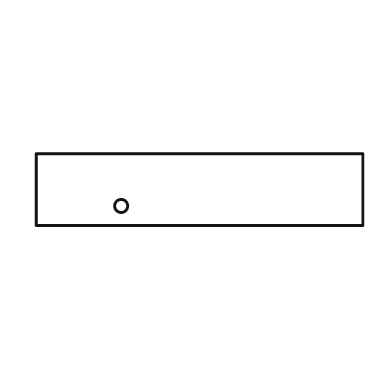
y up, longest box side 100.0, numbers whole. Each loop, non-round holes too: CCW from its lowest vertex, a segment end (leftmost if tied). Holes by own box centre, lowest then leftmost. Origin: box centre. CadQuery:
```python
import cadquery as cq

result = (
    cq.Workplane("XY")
    .moveTo(-50.0, -11.0)
    .lineTo(50.0, -11.0)
    .lineTo(50.0, 11.0)
    .lineTo(-50.0, 11.0)
    .close()
    .moveTo(-24.0, -5.0)
    .circle(2.0)
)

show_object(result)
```